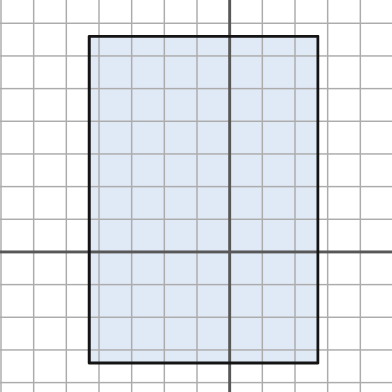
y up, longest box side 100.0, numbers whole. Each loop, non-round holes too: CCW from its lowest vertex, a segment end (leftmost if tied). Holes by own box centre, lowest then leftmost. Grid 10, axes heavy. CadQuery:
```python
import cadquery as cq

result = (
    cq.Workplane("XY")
    .moveTo(-43.0, -34.0)
    .lineTo(27.0, -34.0)
    .lineTo(27.0, 66.0)
    .lineTo(-43.0, 66.0)
    .close()
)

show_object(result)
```